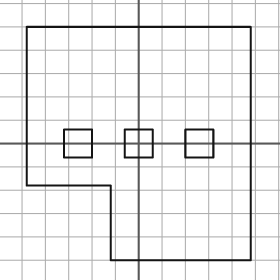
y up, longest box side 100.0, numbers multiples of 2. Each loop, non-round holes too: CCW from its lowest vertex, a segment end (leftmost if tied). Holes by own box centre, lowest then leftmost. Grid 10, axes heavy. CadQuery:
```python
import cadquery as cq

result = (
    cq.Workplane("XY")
    .moveTo(-12.0, -50.0)
    .lineTo(48.0, -50.0)
    .lineTo(48.0, 50.0)
    .lineTo(-48.0, 50.0)
    .lineTo(-48.0, -18.0)
    .lineTo(-12.0, -18.0)
    .close()
    .moveTo(-32.0, -6.0)
    .lineTo(-20.0, -6.0)
    .lineTo(-20.0, 6.0)
    .lineTo(-32.0, 6.0)
    .close()
    .moveTo(-6.0, -6.0)
    .lineTo(6.0, -6.0)
    .lineTo(6.0, 6.0)
    .lineTo(-6.0, 6.0)
    .close()
    .moveTo(20.0, -6.0)
    .lineTo(32.0, -6.0)
    .lineTo(32.0, 6.0)
    .lineTo(20.0, 6.0)
    .close()
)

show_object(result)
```